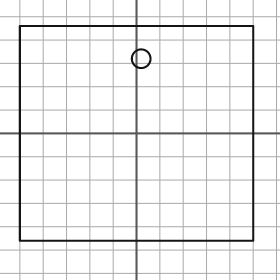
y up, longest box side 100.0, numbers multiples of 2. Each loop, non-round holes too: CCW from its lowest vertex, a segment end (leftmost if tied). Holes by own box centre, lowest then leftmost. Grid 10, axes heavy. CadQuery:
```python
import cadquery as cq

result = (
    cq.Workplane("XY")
    .moveTo(-50.0, -46.0)
    .lineTo(50.0, -46.0)
    .lineTo(50.0, 46.0)
    .lineTo(-50.0, 46.0)
    .close()
    .moveTo(2.0, 32.0)
    .circle(4.0)
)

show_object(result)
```